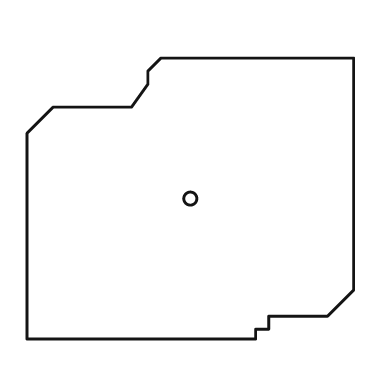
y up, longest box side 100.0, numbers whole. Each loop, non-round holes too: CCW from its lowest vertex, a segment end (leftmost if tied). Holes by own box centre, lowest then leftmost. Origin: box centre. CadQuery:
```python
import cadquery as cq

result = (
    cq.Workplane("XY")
    .moveTo(-50.0, -43.0)
    .lineTo(20.0, -43.0)
    .lineTo(20.0, -40.0)
    .lineTo(24.0, -40.0)
    .lineTo(24.0, -36.0)
    .lineTo(42.0, -36.0)
    .lineTo(50.0, -28.0)
    .lineTo(50.0, 43.0)
    .lineTo(-9.0, 43.0)
    .lineTo(-13.0, 39.0)
    .lineTo(-13.0, 35.0)
    .lineTo(-18.0, 28.0)
    .lineTo(-42.0, 28.0)
    .lineTo(-50.0, 20.0)
    .close()
    .moveTo(0.0, 0.0)
    .circle(2.0)
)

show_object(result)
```